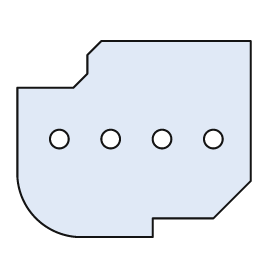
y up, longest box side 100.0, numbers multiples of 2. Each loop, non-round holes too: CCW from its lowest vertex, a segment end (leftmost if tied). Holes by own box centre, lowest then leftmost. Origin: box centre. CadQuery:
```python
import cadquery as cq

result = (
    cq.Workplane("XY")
    .moveTo(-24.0, -42.0)
    .lineTo(8.0, -42.0)
    .lineTo(8.0, -34.0)
    .lineTo(34.0, -34.0)
    .lineTo(50.0, -18.0)
    .lineTo(50.0, 42.0)
    .lineTo(-14.0, 42.0)
    .lineTo(-20.0, 36.0)
    .lineTo(-20.0, 28.0)
    .lineTo(-26.0, 22.0)
    .lineTo(-50.0, 22.0)
    .lineTo(-50.0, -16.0)
    .threePointArc((-42.0, -34.0), (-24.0, -42.0))
    .close()
    .moveTo(-32.0, 0.0)
    .circle(4.0)
    .moveTo(-10.0, 0.0)
    .circle(4.0)
    .moveTo(12.0, 0.0)
    .circle(4.0)
    .moveTo(34.0, 0.0)
    .circle(4.0)
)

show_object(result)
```